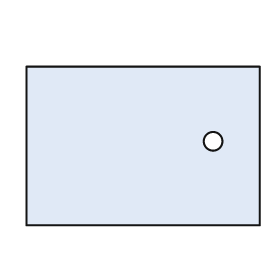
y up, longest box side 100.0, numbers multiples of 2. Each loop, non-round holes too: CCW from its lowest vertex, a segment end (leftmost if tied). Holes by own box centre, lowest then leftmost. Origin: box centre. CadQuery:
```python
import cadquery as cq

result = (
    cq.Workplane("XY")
    .moveTo(-50.0, -34.0)
    .lineTo(50.0, -34.0)
    .lineTo(50.0, 34.0)
    .lineTo(-50.0, 34.0)
    .close()
    .moveTo(30.0, 2.0)
    .circle(4.0)
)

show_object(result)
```